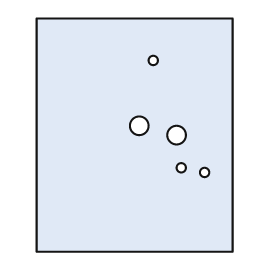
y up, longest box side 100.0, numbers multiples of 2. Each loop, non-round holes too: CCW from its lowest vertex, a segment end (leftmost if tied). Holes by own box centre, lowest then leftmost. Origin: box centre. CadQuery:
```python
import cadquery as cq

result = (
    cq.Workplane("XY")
    .moveTo(-42.0, -50.0)
    .lineTo(42.0, -50.0)
    .lineTo(42.0, 50.0)
    .lineTo(-42.0, 50.0)
    .close()
    .moveTo(30.0, -16.0)
    .circle(2.0)
    .moveTo(20.0, -14.0)
    .circle(2.0)
    .moveTo(18.0, 0.0)
    .circle(4.0)
    .moveTo(2.0, 4.0)
    .circle(4.0)
    .moveTo(8.0, 32.0)
    .circle(2.0)
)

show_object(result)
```